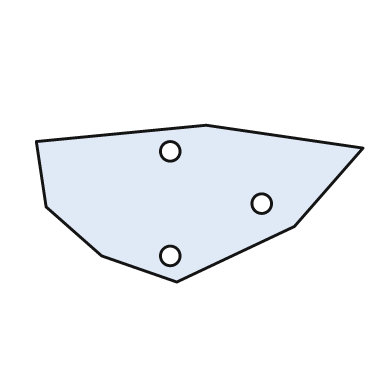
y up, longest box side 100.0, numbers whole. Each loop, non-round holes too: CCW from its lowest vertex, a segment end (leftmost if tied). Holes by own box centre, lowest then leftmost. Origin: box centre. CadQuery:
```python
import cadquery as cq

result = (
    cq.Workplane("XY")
    .moveTo(-7.0, -24.0)
    .lineTo(29.0, -7.0)
    .lineTo(50.0, 17.0)
    .lineTo(2.0, 24.0)
    .lineTo(-50.0, 19.0)
    .lineTo(-47.0, -1.0)
    .lineTo(-30.0, -16.0)
    .close()
    .moveTo(-9.0, -16.0)
    .circle(3.0)
    .moveTo(19.0, 0.0)
    .circle(3.0)
    .moveTo(-9.0, 16.0)
    .circle(3.0)
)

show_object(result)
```